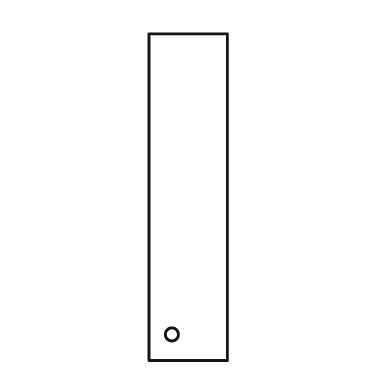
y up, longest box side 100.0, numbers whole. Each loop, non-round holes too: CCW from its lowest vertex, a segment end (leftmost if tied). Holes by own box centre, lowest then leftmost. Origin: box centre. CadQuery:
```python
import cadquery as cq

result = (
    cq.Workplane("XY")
    .moveTo(-12.0, -50.0)
    .lineTo(12.0, -50.0)
    .lineTo(12.0, 50.0)
    .lineTo(-12.0, 50.0)
    .close()
    .moveTo(-5.0, -42.0)
    .circle(2.0)
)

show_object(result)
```